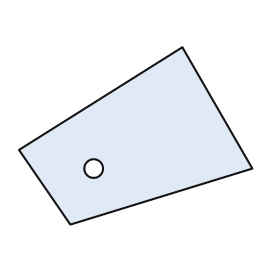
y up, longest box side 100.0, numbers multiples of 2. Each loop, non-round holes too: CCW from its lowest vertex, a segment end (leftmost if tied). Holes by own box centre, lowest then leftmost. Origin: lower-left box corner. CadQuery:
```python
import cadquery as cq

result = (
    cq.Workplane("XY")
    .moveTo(22.0, 0.0)
    .lineTo(100.0, 24.0)
    .lineTo(70.0, 76.0)
    .lineTo(0.0, 32.0)
    .close()
    .moveTo(32.0, 24.0)
    .circle(4.0)
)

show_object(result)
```